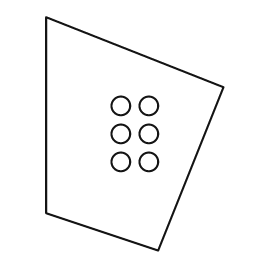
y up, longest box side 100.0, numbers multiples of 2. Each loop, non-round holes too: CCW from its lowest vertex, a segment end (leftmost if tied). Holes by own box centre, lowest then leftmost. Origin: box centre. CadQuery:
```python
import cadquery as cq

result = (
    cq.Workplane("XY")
    .moveTo(10.0, -50.0)
    .lineTo(38.0, 20.0)
    .lineTo(-38.0, 50.0)
    .lineTo(-38.0, -34.0)
    .close()
    .moveTo(-6.0, -12.0)
    .circle(4.0)
    .moveTo(6.0, -12.0)
    .circle(4.0)
    .moveTo(-6.0, 0.0)
    .circle(4.0)
    .moveTo(6.0, 0.0)
    .circle(4.0)
    .moveTo(-6.0, 12.0)
    .circle(4.0)
    .moveTo(6.0, 12.0)
    .circle(4.0)
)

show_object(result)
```